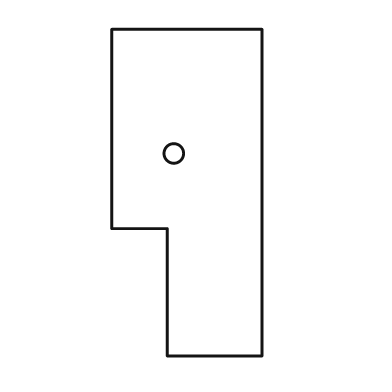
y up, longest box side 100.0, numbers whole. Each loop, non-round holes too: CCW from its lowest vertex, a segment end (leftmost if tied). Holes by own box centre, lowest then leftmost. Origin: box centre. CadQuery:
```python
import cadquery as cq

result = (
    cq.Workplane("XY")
    .moveTo(-6.0, -50.0)
    .lineTo(23.0, -50.0)
    .lineTo(23.0, 50.0)
    .lineTo(-23.0, 50.0)
    .lineTo(-23.0, -11.0)
    .lineTo(-6.0, -11.0)
    .close()
    .moveTo(-4.0, 12.0)
    .circle(3.0)
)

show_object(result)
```